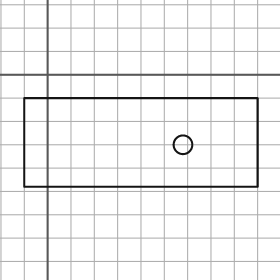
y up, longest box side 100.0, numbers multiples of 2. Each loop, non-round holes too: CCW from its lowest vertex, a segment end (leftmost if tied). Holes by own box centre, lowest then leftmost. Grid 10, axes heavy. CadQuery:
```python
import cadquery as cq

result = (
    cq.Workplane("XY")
    .moveTo(-10.0, -48.0)
    .lineTo(90.0, -48.0)
    .lineTo(90.0, -10.0)
    .lineTo(-10.0, -10.0)
    .close()
    .moveTo(58.0, -30.0)
    .circle(4.0)
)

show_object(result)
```